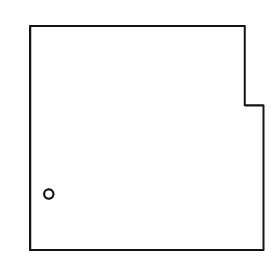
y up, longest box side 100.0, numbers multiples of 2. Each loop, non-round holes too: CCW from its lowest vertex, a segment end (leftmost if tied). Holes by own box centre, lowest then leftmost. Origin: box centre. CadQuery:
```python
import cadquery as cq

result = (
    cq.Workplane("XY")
    .moveTo(-50.0, -48.0)
    .lineTo(50.0, -48.0)
    .lineTo(50.0, 14.0)
    .lineTo(42.0, 14.0)
    .lineTo(42.0, 48.0)
    .lineTo(-50.0, 48.0)
    .close()
    .moveTo(-42.0, -24.0)
    .circle(2.0)
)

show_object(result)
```